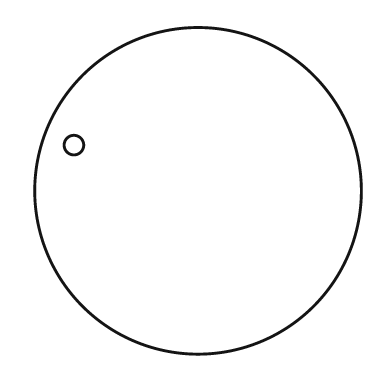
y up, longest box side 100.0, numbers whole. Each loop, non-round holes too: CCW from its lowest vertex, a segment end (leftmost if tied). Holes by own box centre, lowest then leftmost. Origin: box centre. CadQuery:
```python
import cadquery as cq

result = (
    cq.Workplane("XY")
    .moveTo(0.0, 0.0)
    .circle(50.0)
    .moveTo(-38.0, 14.0)
    .circle(3.0)
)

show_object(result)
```